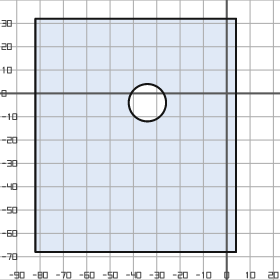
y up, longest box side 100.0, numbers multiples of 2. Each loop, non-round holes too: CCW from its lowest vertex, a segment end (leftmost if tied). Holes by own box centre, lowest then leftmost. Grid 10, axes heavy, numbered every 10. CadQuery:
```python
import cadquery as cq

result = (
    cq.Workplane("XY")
    .moveTo(-82.0, -68.0)
    .lineTo(4.0, -68.0)
    .lineTo(4.0, 32.0)
    .lineTo(-82.0, 32.0)
    .close()
    .moveTo(-34.0, -4.0)
    .circle(8.0)
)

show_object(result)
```